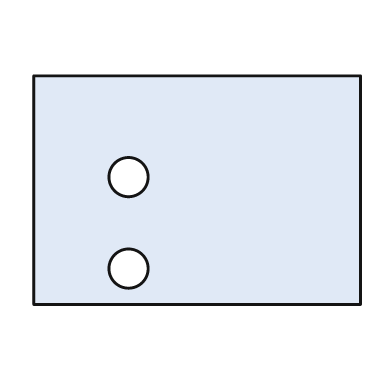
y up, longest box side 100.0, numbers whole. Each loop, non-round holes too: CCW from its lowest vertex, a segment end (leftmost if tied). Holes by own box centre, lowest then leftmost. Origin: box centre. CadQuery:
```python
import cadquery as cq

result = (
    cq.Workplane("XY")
    .moveTo(-50.0, -35.0)
    .lineTo(50.0, -35.0)
    .lineTo(50.0, 35.0)
    .lineTo(-50.0, 35.0)
    .close()
    .moveTo(-21.0, -24.0)
    .circle(6.0)
    .moveTo(-21.0, 4.0)
    .circle(6.0)
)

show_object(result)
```